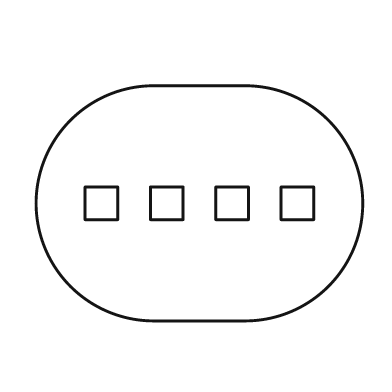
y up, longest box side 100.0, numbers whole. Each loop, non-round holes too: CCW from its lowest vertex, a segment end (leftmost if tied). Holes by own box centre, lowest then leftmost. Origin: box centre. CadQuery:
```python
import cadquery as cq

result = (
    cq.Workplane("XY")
    .moveTo(-14.0, -36.0)
    .lineTo(14.0, -36.0)
    .threePointArc((50.0, 0.0), (14.0, 36.0))
    .lineTo(-14.0, 36.0)
    .threePointArc((-50.0, 0.0), (-14.0, -36.0))
    .close()
    .moveTo(-35.0, -5.0)
    .lineTo(-25.0, -5.0)
    .lineTo(-25.0, 5.0)
    .lineTo(-35.0, 5.0)
    .close()
    .moveTo(-15.0, -5.0)
    .lineTo(-5.0, -5.0)
    .lineTo(-5.0, 5.0)
    .lineTo(-15.0, 5.0)
    .close()
    .moveTo(5.0, -5.0)
    .lineTo(15.0, -5.0)
    .lineTo(15.0, 5.0)
    .lineTo(5.0, 5.0)
    .close()
    .moveTo(25.0, -5.0)
    .lineTo(35.0, -5.0)
    .lineTo(35.0, 5.0)
    .lineTo(25.0, 5.0)
    .close()
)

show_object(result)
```